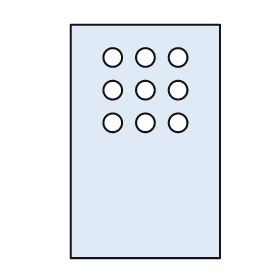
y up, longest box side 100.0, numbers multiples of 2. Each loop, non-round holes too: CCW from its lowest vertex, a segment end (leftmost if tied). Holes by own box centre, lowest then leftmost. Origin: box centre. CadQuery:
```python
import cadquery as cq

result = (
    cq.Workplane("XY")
    .moveTo(-32.0, -50.0)
    .lineTo(32.0, -50.0)
    .lineTo(32.0, 50.0)
    .lineTo(-32.0, 50.0)
    .close()
    .moveTo(-14.0, 8.0)
    .circle(4.0)
    .moveTo(0.0, 8.0)
    .circle(4.0)
    .moveTo(14.0, 8.0)
    .circle(4.0)
    .moveTo(-14.0, 22.0)
    .circle(4.0)
    .moveTo(0.0, 22.0)
    .circle(4.0)
    .moveTo(14.0, 22.0)
    .circle(4.0)
    .moveTo(-14.0, 36.0)
    .circle(4.0)
    .moveTo(0.0, 36.0)
    .circle(4.0)
    .moveTo(14.0, 36.0)
    .circle(4.0)
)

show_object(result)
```